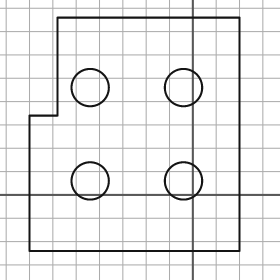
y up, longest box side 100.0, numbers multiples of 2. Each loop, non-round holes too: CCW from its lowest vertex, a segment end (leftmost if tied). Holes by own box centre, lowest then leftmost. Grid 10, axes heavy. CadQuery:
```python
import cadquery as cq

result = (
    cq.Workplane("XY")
    .moveTo(-70.0, -24.0)
    .lineTo(20.0, -24.0)
    .lineTo(20.0, 76.0)
    .lineTo(-58.0, 76.0)
    .lineTo(-58.0, 34.0)
    .lineTo(-70.0, 34.0)
    .close()
    .moveTo(-44.0, 6.0)
    .circle(8.0)
    .moveTo(-4.0, 6.0)
    .circle(8.0)
    .moveTo(-44.0, 46.0)
    .circle(8.0)
    .moveTo(-4.0, 46.0)
    .circle(8.0)
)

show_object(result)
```